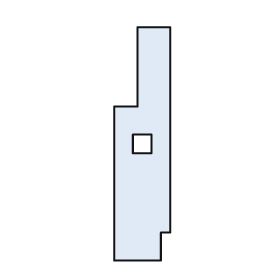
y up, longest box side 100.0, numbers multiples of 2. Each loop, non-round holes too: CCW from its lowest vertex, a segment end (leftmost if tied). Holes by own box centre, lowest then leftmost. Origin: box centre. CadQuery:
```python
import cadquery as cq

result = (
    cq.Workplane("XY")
    .moveTo(-12.0, -50.0)
    .lineTo(8.0, -50.0)
    .lineTo(8.0, -38.0)
    .lineTo(12.0, -38.0)
    .lineTo(12.0, 50.0)
    .lineTo(-2.0, 50.0)
    .lineTo(-2.0, 16.0)
    .lineTo(-12.0, 16.0)
    .close()
    .moveTo(-4.0, -4.0)
    .lineTo(4.0, -4.0)
    .lineTo(4.0, 4.0)
    .lineTo(-4.0, 4.0)
    .close()
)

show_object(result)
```